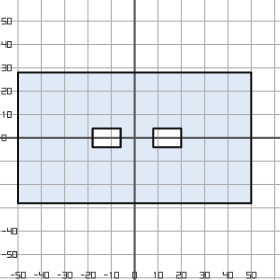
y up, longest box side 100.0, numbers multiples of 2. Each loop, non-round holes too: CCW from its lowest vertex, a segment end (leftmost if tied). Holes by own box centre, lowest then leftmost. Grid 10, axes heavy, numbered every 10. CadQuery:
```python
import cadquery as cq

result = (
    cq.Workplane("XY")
    .moveTo(-50.0, -28.0)
    .lineTo(50.0, -28.0)
    .lineTo(50.0, 28.0)
    .lineTo(-50.0, 28.0)
    .close()
    .moveTo(-18.0, -4.0)
    .lineTo(-6.0, -4.0)
    .lineTo(-6.0, 4.0)
    .lineTo(-18.0, 4.0)
    .close()
    .moveTo(8.0, -4.0)
    .lineTo(20.0, -4.0)
    .lineTo(20.0, 4.0)
    .lineTo(8.0, 4.0)
    .close()
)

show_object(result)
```